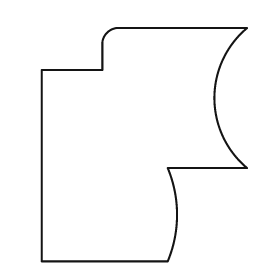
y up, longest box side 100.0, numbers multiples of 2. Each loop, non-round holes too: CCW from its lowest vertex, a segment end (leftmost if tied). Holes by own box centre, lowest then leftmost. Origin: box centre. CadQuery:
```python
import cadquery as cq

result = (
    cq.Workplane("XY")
    .moveTo(-44.0, -50.0)
    .lineTo(10.0, -50.0)
    .threePointArc((14.0, -30.0), (10.0, -10.0))
    .lineTo(44.0, -10.0)
    .threePointArc((30.0, 20.0), (44.0, 50.0))
    .lineTo(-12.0, 50.0)
    .threePointArc((-16.0, 48.0), (-18.0, 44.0))
    .lineTo(-18.0, 32.0)
    .lineTo(-44.0, 32.0)
    .close()
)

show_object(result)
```